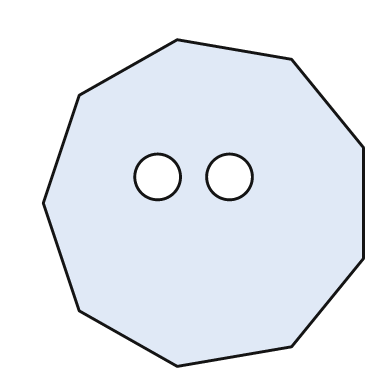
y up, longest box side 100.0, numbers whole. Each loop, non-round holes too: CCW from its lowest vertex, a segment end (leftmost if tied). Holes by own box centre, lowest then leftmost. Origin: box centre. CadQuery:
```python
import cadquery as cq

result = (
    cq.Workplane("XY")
    .moveTo(-8.0, -50.0)
    .lineTo(27.0, -44.0)
    .lineTo(49.0, -17.0)
    .lineTo(49.0, 17.0)
    .lineTo(27.0, 44.0)
    .lineTo(-8.0, 50.0)
    .lineTo(-38.0, 33.0)
    .lineTo(-49.0, 0.0)
    .lineTo(-38.0, -33.0)
    .close()
    .moveTo(-14.0, 8.0)
    .circle(7.0)
    .moveTo(8.0, 8.0)
    .circle(7.0)
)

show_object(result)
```